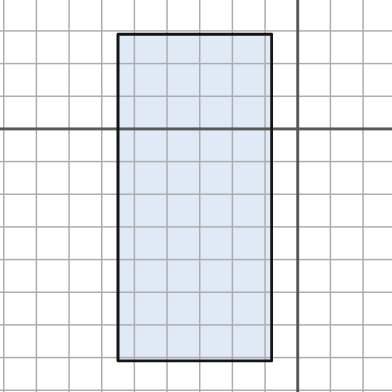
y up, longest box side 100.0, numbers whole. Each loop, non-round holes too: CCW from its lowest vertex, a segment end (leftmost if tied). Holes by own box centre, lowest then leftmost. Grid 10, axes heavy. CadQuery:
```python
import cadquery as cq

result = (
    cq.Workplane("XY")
    .moveTo(-55.0, -71.0)
    .lineTo(-8.0, -71.0)
    .lineTo(-8.0, 29.0)
    .lineTo(-55.0, 29.0)
    .close()
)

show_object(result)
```